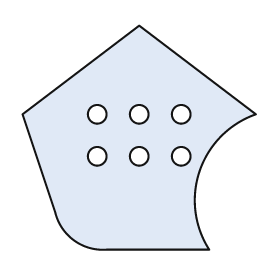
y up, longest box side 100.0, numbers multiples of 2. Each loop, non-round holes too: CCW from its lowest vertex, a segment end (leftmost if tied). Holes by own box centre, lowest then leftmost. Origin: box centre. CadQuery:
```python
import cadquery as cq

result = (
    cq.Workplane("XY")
    .moveTo(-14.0, -48.0)
    .lineTo(30.0, -48.0)
    .threePointArc((26.0, -14.0), (50.0, 10.0))
    .lineTo(0.0, 48.0)
    .lineTo(-50.0, 10.0)
    .lineTo(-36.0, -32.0)
    .threePointArc((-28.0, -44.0), (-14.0, -48.0))
    .close()
    .moveTo(-18.0, -8.0)
    .circle(4.0)
    .moveTo(0.0, -8.0)
    .circle(4.0)
    .moveTo(18.0, -8.0)
    .circle(4.0)
    .moveTo(-18.0, 10.0)
    .circle(4.0)
    .moveTo(0.0, 10.0)
    .circle(4.0)
    .moveTo(18.0, 10.0)
    .circle(4.0)
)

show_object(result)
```